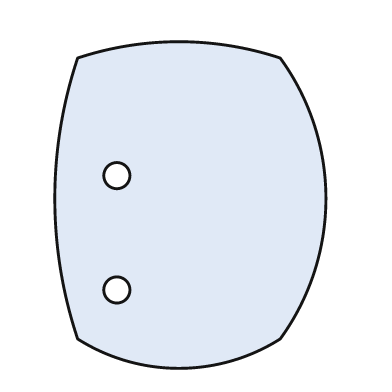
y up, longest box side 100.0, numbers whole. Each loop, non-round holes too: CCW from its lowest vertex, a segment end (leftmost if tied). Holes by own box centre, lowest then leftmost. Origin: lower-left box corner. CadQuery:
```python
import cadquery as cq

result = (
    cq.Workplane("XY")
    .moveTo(7.0, 9.0)
    .threePointArc((38.0, 0.0), (69.0, 9.0))
    .threePointArc((83.0, 52.0), (69.0, 95.0))
    .threePointArc((38.0, 100.0), (7.0, 95.0))
    .threePointArc((0.0, 52.0), (7.0, 9.0))
    .close()
    .moveTo(19.0, 24.0)
    .circle(4.0)
    .moveTo(19.0, 59.0)
    .circle(4.0)
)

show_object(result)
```